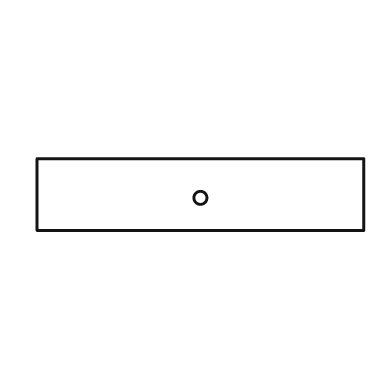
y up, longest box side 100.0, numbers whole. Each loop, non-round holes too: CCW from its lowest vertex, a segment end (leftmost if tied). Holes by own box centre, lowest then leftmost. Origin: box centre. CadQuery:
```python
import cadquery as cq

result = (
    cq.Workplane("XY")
    .moveTo(-50.0, -11.0)
    .lineTo(50.0, -11.0)
    .lineTo(50.0, 11.0)
    .lineTo(-50.0, 11.0)
    .close()
    .moveTo(0.0, -1.0)
    .circle(2.0)
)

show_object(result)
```